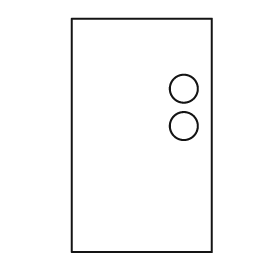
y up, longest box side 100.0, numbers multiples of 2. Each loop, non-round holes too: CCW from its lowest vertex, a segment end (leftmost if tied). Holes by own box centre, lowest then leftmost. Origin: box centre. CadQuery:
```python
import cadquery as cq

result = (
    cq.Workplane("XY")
    .moveTo(-30.0, -50.0)
    .lineTo(30.0, -50.0)
    .lineTo(30.0, 50.0)
    .lineTo(-30.0, 50.0)
    .close()
    .moveTo(18.0, 4.0)
    .circle(6.0)
    .moveTo(18.0, 20.0)
    .circle(6.0)
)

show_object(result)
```